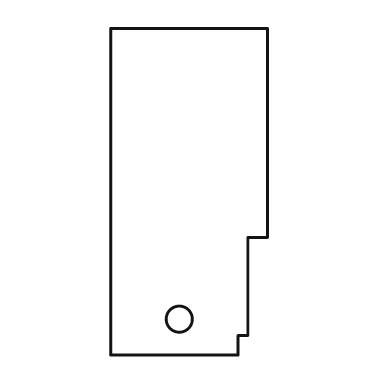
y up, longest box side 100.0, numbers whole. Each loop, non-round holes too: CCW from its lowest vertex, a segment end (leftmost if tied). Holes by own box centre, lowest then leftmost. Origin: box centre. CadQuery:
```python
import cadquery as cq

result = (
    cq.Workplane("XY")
    .moveTo(-24.0, -50.0)
    .lineTo(15.0, -50.0)
    .lineTo(15.0, -44.0)
    .lineTo(18.0, -44.0)
    .lineTo(18.0, -14.0)
    .lineTo(24.0, -14.0)
    .lineTo(24.0, 50.0)
    .lineTo(-24.0, 50.0)
    .close()
    .moveTo(-3.0, -39.0)
    .circle(4.0)
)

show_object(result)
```